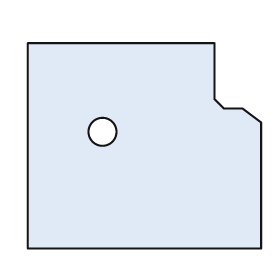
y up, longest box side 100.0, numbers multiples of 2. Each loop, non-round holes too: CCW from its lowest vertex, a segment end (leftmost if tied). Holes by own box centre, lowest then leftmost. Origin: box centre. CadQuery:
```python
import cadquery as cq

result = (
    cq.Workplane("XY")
    .moveTo(-50.0, -44.0)
    .lineTo(50.0, -44.0)
    .lineTo(50.0, 10.0)
    .lineTo(42.0, 16.0)
    .lineTo(34.0, 16.0)
    .lineTo(30.0, 20.0)
    .lineTo(30.0, 44.0)
    .lineTo(-50.0, 44.0)
    .close()
    .moveTo(-18.0, 6.0)
    .circle(6.0)
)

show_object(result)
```